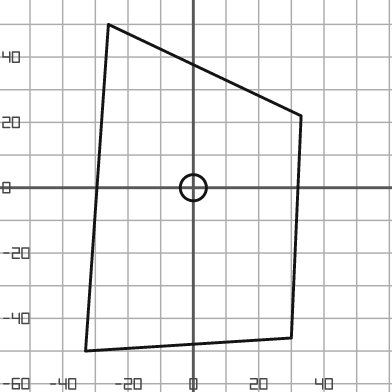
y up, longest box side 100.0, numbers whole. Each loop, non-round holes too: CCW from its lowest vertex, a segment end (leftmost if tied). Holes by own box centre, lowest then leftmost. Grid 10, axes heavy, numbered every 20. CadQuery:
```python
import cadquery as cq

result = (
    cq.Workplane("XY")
    .moveTo(-33.0, -50.0)
    .lineTo(30.0, -46.0)
    .lineTo(33.0, 22.0)
    .lineTo(-26.0, 50.0)
    .close()
    .moveTo(0.0, 0.0)
    .circle(4.0)
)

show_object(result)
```